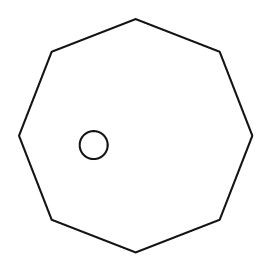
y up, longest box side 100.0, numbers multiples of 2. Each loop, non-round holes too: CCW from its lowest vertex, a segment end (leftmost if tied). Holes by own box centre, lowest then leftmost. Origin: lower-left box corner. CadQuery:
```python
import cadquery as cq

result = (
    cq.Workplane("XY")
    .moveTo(50.0, 0.0)
    .lineTo(86.0, 14.0)
    .lineTo(100.0, 50.0)
    .lineTo(86.0, 86.0)
    .lineTo(50.0, 100.0)
    .lineTo(14.0, 86.0)
    .lineTo(0.0, 50.0)
    .lineTo(14.0, 14.0)
    .close()
    .moveTo(32.0, 46.0)
    .circle(6.0)
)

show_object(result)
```